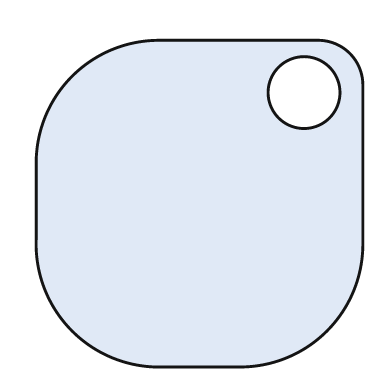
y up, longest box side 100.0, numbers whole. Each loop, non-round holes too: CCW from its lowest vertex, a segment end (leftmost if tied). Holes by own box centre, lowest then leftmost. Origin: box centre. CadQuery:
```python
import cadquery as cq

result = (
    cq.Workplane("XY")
    .moveTo(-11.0, -50.0)
    .lineTo(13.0, -50.0)
    .threePointArc((39.0, -39.0), (50.0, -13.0))
    .lineTo(50.0, 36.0)
    .threePointArc((46.0, 46.0), (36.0, 50.0))
    .lineTo(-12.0, 50.0)
    .threePointArc((-39.0, 39.0), (-50.0, 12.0))
    .lineTo(-50.0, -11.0)
    .threePointArc((-39.0, -39.0), (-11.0, -50.0))
    .close()
    .moveTo(32.0, 34.0)
    .circle(11.0)
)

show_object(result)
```